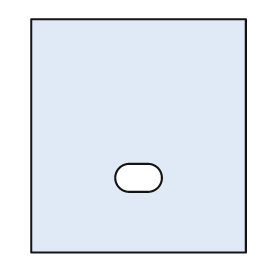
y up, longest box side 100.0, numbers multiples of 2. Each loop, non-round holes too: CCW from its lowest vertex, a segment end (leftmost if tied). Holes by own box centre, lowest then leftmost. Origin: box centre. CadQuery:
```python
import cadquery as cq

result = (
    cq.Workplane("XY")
    .moveTo(-46.0, -50.0)
    .lineTo(46.0, -50.0)
    .lineTo(46.0, 50.0)
    .lineTo(-46.0, 50.0)
    .close()
    .moveTo(-4.0, -24.0)
    .lineTo(4.0, -24.0)
    .threePointArc((10.0, -18.0), (4.0, -12.0))
    .lineTo(-4.0, -12.0)
    .threePointArc((-10.0, -18.0), (-4.0, -24.0))
    .close()
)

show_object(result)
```